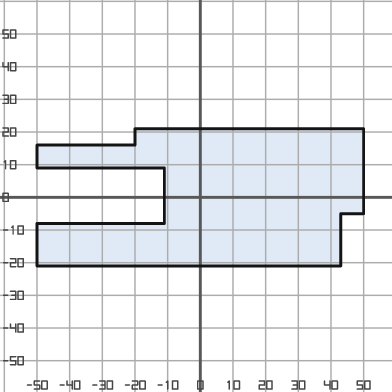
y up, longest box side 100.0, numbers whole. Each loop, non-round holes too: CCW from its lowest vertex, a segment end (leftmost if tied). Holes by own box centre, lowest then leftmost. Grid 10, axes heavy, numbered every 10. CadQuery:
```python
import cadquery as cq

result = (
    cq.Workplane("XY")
    .moveTo(-50.0, -21.0)
    .lineTo(43.0, -21.0)
    .lineTo(43.0, -5.0)
    .lineTo(50.0, -5.0)
    .lineTo(50.0, 21.0)
    .lineTo(-20.0, 21.0)
    .lineTo(-20.0, 16.0)
    .lineTo(-50.0, 16.0)
    .lineTo(-50.0, 9.0)
    .lineTo(-11.0, 9.0)
    .lineTo(-11.0, -8.0)
    .lineTo(-50.0, -8.0)
    .close()
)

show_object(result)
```